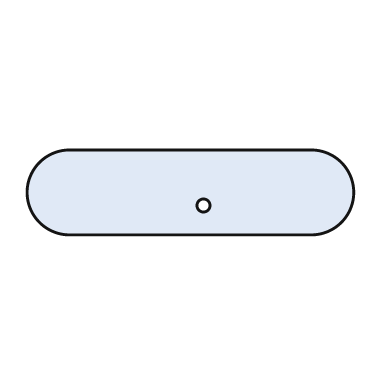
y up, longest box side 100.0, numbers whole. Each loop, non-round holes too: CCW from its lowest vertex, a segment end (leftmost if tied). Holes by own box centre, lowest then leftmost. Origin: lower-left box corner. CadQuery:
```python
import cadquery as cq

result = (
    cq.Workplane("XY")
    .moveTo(13.0, 0.0)
    .lineTo(87.0, 0.0)
    .threePointArc((100.0, 13.0), (87.0, 26.0))
    .lineTo(13.0, 26.0)
    .threePointArc((0.0, 13.0), (13.0, 0.0))
    .close()
    .moveTo(54.0, 9.0)
    .circle(2.0)
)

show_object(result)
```